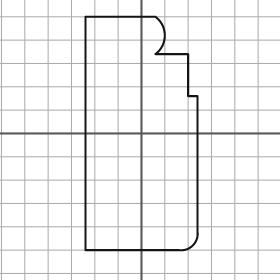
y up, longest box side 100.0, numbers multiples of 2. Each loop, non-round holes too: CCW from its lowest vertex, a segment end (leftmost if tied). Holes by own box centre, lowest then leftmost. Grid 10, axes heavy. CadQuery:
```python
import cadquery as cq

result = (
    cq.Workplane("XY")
    .moveTo(-24.0, -50.0)
    .lineTo(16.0, -50.0)
    .threePointArc((22.0, -48.0), (24.0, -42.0))
    .lineTo(24.0, 16.0)
    .lineTo(20.0, 16.0)
    .lineTo(20.0, 34.0)
    .lineTo(6.0, 34.0)
    .threePointArc((10.0, 42.0), (6.0, 50.0))
    .lineTo(-24.0, 50.0)
    .close()
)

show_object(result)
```